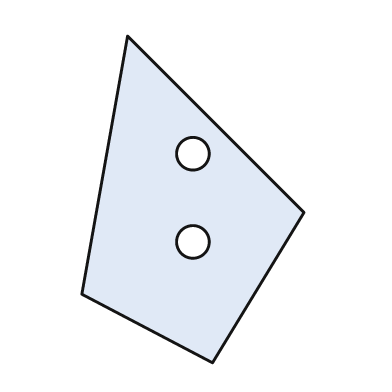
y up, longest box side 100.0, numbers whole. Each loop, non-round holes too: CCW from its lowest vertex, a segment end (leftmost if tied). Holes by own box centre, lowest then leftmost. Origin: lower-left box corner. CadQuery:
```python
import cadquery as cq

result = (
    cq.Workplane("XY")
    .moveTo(40.0, 0.0)
    .lineTo(68.0, 46.0)
    .lineTo(14.0, 100.0)
    .lineTo(0.0, 21.0)
    .close()
    .moveTo(34.0, 37.0)
    .circle(5.0)
    .moveTo(34.0, 64.0)
    .circle(5.0)
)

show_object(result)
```